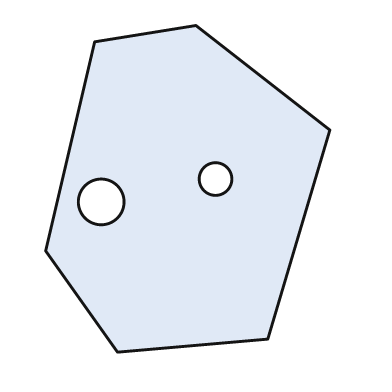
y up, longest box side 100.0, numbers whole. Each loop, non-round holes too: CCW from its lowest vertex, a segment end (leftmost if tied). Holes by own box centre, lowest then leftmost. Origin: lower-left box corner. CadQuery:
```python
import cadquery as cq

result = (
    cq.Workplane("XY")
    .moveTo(22.0, 0.0)
    .lineTo(68.0, 4.0)
    .lineTo(87.0, 68.0)
    .lineTo(46.0, 100.0)
    .lineTo(15.0, 95.0)
    .lineTo(0.0, 31.0)
    .close()
    .moveTo(17.0, 46.0)
    .circle(7.0)
    .moveTo(52.0, 53.0)
    .circle(5.0)
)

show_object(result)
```